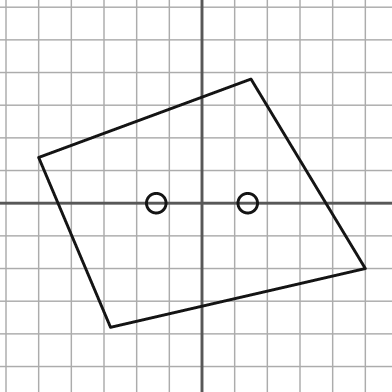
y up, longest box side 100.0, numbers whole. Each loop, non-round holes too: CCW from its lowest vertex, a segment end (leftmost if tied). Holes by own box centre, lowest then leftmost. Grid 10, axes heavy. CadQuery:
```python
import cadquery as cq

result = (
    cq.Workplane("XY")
    .moveTo(-28.0, -38.0)
    .lineTo(50.0, -20.0)
    .lineTo(15.0, 38.0)
    .lineTo(-50.0, 14.0)
    .close()
    .moveTo(-14.0, 0.0)
    .circle(3.0)
    .moveTo(14.0, 0.0)
    .circle(3.0)
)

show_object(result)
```